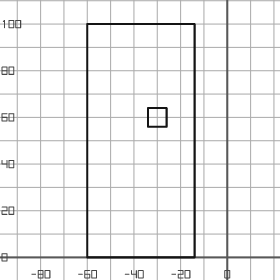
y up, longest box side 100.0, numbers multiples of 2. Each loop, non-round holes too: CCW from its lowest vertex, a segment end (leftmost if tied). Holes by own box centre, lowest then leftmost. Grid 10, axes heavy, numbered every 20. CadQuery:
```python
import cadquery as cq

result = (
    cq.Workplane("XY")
    .moveTo(-60.0, 0.0)
    .lineTo(-14.0, 0.0)
    .lineTo(-14.0, 100.0)
    .lineTo(-60.0, 100.0)
    .close()
    .moveTo(-34.0, 56.0)
    .lineTo(-26.0, 56.0)
    .lineTo(-26.0, 64.0)
    .lineTo(-34.0, 64.0)
    .close()
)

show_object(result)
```